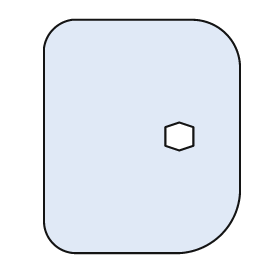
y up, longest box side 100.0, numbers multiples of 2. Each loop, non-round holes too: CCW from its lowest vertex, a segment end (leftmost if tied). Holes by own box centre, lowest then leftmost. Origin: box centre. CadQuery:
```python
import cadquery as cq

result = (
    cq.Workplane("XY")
    .moveTo(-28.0, -50.0)
    .lineTo(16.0, -50.0)
    .threePointArc((34.0, -42.0), (42.0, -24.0))
    .lineTo(42.0, 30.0)
    .threePointArc((36.0, 44.0), (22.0, 50.0))
    .lineTo(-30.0, 50.0)
    .threePointArc((-38.0, 46.0), (-42.0, 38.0))
    .lineTo(-42.0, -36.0)
    .threePointArc((-38.0, -46.0), (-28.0, -50.0))
    .close()
    .moveTo(16.0, -6.0)
    .lineTo(22.0, -4.0)
    .lineTo(22.0, 4.0)
    .lineTo(16.0, 6.0)
    .lineTo(10.0, 4.0)
    .lineTo(10.0, -4.0)
    .close()
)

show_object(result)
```